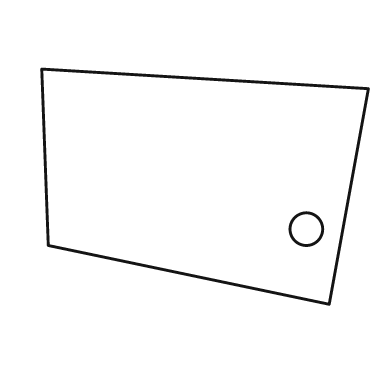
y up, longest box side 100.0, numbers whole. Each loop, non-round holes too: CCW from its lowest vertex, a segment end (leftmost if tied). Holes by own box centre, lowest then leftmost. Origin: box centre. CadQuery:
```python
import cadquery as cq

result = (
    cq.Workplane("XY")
    .moveTo(38.0, -36.0)
    .lineTo(50.0, 30.0)
    .lineTo(-50.0, 36.0)
    .lineTo(-48.0, -18.0)
    .close()
    .moveTo(31.0, -13.0)
    .circle(5.0)
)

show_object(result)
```